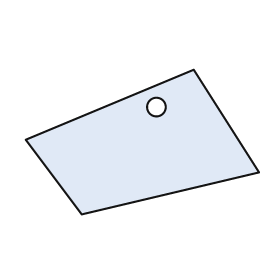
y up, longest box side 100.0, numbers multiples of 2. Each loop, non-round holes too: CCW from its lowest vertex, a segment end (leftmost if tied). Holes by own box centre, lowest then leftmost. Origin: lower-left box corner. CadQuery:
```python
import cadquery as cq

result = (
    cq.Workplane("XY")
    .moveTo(24.0, 0.0)
    .lineTo(100.0, 18.0)
    .lineTo(72.0, 62.0)
    .lineTo(0.0, 32.0)
    .close()
    .moveTo(56.0, 46.0)
    .circle(4.0)
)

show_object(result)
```